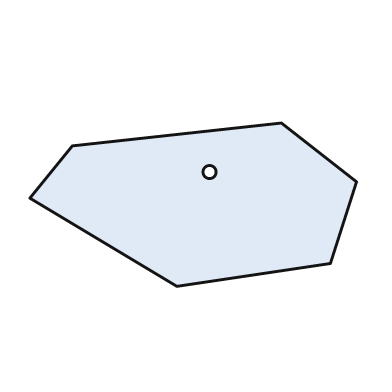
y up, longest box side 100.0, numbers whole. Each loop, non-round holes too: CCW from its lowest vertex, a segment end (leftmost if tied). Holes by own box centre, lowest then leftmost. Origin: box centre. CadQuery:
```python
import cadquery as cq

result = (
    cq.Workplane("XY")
    .moveTo(-5.0, -25.0)
    .lineTo(42.0, -18.0)
    .lineTo(50.0, 7.0)
    .lineTo(27.0, 25.0)
    .lineTo(-37.0, 18.0)
    .lineTo(-50.0, 2.0)
    .close()
    .moveTo(5.0, 10.0)
    .circle(2.0)
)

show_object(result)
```